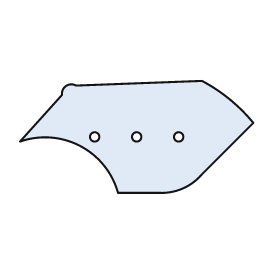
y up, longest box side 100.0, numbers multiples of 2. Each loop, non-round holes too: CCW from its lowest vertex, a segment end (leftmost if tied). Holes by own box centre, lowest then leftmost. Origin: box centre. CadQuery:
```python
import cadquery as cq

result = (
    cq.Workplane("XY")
    .moveTo(-8.0, -24.0)
    .lineTo(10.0, -24.0)
    .threePointArc((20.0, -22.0), (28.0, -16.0))
    .lineTo(50.0, 6.0)
    .threePointArc((40.0, 16.0), (28.0, 24.0))
    .lineTo(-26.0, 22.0)
    .threePointArc((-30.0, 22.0), (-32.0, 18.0))
    .lineTo(-50.0, -2.0)
    .threePointArc((-24.0, -4.0), (-8.0, -24.0))
    .close()
    .moveTo(-18.0, 0.0)
    .circle(2.0)
    .moveTo(0.0, 0.0)
    .circle(2.0)
    .moveTo(18.0, 0.0)
    .circle(2.0)
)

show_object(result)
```